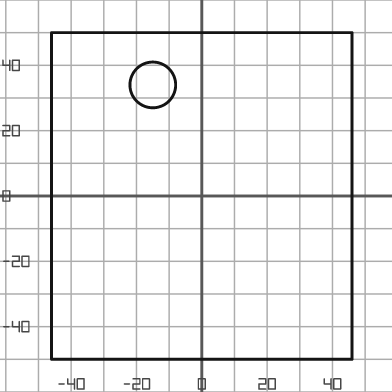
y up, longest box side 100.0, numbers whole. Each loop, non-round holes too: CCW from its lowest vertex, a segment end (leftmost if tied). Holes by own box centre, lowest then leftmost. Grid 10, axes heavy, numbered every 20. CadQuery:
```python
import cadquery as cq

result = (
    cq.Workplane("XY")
    .moveTo(-46.0, -50.0)
    .lineTo(46.0, -50.0)
    .lineTo(46.0, 50.0)
    .lineTo(-46.0, 50.0)
    .close()
    .moveTo(-15.0, 34.0)
    .circle(7.0)
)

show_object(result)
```